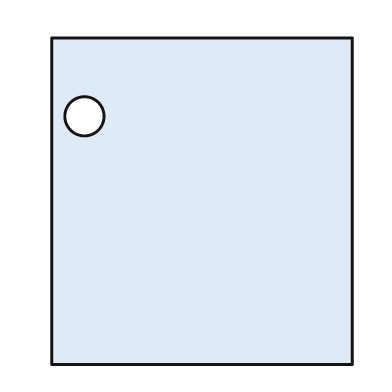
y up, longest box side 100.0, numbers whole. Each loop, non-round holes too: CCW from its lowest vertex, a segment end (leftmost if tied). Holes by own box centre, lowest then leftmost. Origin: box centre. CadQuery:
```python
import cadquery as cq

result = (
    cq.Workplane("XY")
    .moveTo(-46.0, -50.0)
    .lineTo(46.0, -50.0)
    .lineTo(46.0, 50.0)
    .lineTo(-46.0, 50.0)
    .close()
    .moveTo(-36.0, 26.0)
    .circle(6.0)
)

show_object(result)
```